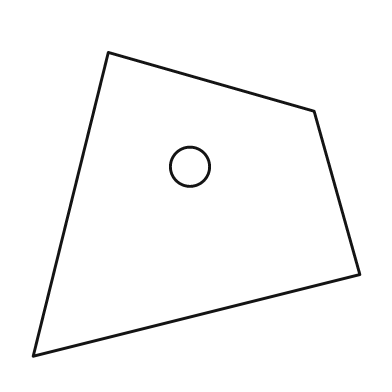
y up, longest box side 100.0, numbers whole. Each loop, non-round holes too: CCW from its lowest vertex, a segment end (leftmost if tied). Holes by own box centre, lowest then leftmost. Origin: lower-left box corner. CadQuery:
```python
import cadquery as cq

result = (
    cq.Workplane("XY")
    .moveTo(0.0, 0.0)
    .lineTo(100.0, 25.0)
    .lineTo(86.0, 75.0)
    .lineTo(23.0, 93.0)
    .close()
    .moveTo(48.0, 58.0)
    .circle(6.0)
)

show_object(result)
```